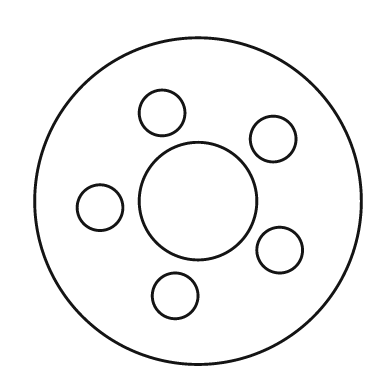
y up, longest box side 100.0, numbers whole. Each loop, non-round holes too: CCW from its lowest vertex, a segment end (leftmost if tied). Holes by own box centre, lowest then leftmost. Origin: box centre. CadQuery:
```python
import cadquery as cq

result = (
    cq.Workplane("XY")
    .moveTo(0.0, 0.0)
    .circle(50.0)
    .moveTo(-7.0, -29.0)
    .circle(7.0)
    .moveTo(25.0, -15.0)
    .circle(7.0)
    .moveTo(-30.0, -2.0)
    .circle(7.0)
    .moveTo(0.0, 0.0)
    .circle(18.0)
    .moveTo(23.0, 19.0)
    .circle(7.0)
    .moveTo(-11.0, 27.0)
    .circle(7.0)
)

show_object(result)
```